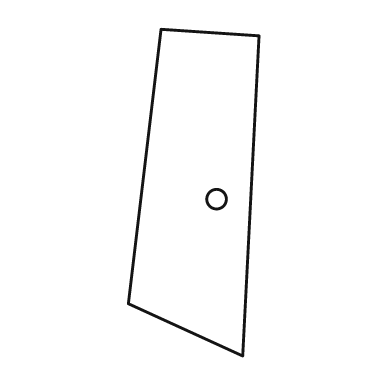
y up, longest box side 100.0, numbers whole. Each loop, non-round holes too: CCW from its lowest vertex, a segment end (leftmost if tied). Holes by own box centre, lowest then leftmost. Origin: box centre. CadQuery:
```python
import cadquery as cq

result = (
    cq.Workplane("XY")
    .moveTo(15.0, -50.0)
    .lineTo(20.0, 48.0)
    .lineTo(-10.0, 50.0)
    .lineTo(-20.0, -34.0)
    .close()
    .moveTo(7.0, -2.0)
    .circle(3.0)
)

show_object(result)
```